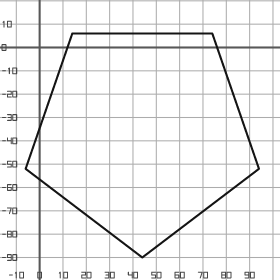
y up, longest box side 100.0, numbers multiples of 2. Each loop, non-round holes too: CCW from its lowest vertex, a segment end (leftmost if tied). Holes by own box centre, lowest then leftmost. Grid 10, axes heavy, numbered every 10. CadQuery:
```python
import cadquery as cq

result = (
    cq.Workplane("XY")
    .moveTo(44.0, -90.0)
    .lineTo(94.0, -52.0)
    .lineTo(74.0, 6.0)
    .lineTo(14.0, 6.0)
    .lineTo(-6.0, -52.0)
    .close()
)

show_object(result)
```